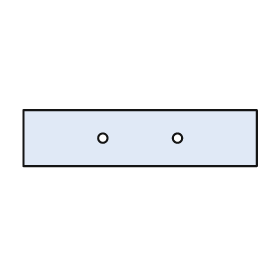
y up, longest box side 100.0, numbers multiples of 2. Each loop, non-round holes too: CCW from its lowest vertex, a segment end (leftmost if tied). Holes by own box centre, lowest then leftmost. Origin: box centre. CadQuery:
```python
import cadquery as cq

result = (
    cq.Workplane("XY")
    .moveTo(-50.0, -12.0)
    .lineTo(50.0, -12.0)
    .lineTo(50.0, 12.0)
    .lineTo(-50.0, 12.0)
    .close()
    .moveTo(-16.0, 0.0)
    .circle(2.0)
    .moveTo(16.0, 0.0)
    .circle(2.0)
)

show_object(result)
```